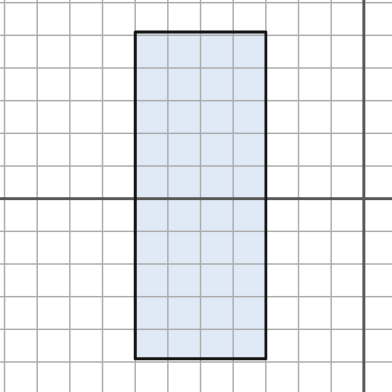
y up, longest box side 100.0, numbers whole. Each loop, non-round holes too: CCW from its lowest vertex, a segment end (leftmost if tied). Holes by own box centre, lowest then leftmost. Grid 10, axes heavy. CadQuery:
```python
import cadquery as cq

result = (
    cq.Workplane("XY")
    .moveTo(-70.0, -49.0)
    .lineTo(-30.0, -49.0)
    .lineTo(-30.0, 51.0)
    .lineTo(-70.0, 51.0)
    .close()
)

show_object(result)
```